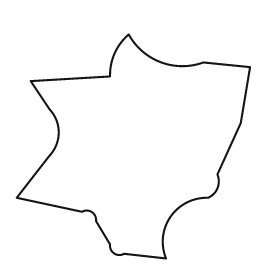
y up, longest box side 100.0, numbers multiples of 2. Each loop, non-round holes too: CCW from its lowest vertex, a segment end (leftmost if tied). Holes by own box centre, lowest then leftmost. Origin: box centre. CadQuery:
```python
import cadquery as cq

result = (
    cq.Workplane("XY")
    .moveTo(14.0, -48.0)
    .threePointArc((16.0, -30.0), (32.0, -22.0))
    .threePointArc((36.0, -18.0), (36.0, -12.0))
    .lineTo(46.0, 10.0)
    .lineTo(50.0, 34.0)
    .lineTo(30.0, 36.0)
    .threePointArc((12.0, 36.0), (-2.0, 48.0))
    .threePointArc((-8.0, 40.0), (-10.0, 30.0))
    .lineTo(-44.0, 28.0)
    .lineTo(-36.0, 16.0)
    .threePointArc((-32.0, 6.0), (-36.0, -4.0))
    .lineTo(-50.0, -22.0)
    .lineTo(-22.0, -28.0)
    .threePointArc((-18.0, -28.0), (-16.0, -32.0))
    .lineTo(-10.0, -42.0)
    .threePointArc((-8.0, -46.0), (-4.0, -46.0))
    .close()
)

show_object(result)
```